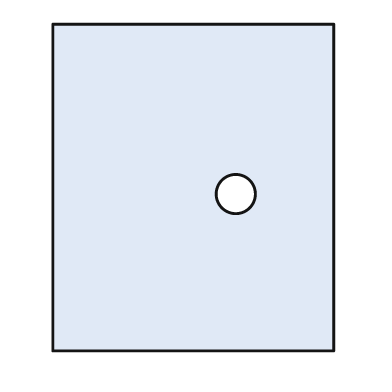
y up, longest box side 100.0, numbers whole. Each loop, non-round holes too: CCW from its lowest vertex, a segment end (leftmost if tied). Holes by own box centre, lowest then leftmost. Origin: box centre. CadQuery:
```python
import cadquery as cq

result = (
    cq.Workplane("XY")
    .moveTo(-43.0, -50.0)
    .lineTo(43.0, -50.0)
    .lineTo(43.0, 50.0)
    .lineTo(-43.0, 50.0)
    .close()
    .moveTo(13.0, -2.0)
    .circle(6.0)
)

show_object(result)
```